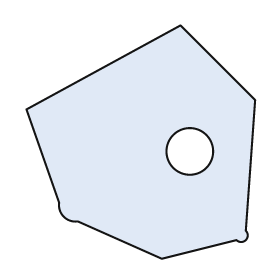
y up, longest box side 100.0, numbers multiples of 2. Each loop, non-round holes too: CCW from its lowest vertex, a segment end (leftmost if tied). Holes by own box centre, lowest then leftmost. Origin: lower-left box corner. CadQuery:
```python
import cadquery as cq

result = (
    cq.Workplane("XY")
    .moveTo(58.0, 0.0)
    .lineTo(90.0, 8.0)
    .threePointArc((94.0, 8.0), (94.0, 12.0))
    .lineTo(98.0, 68.0)
    .lineTo(66.0, 100.0)
    .lineTo(0.0, 64.0)
    .lineTo(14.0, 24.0)
    .threePointArc((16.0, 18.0), (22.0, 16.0))
    .close()
    .moveTo(70.0, 46.0)
    .circle(10.0)
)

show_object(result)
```